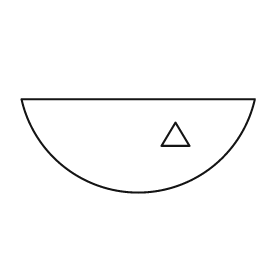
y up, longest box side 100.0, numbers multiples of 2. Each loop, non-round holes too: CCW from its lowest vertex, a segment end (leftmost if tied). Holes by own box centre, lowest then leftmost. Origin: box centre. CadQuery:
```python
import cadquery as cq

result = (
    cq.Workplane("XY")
    .moveTo(-50.0, 20.0)
    .threePointArc((0.0, -20.0), (50.0, 20.0))
    .close()
    .moveTo(10.0, 0.0)
    .lineTo(22.0, 0.0)
    .lineTo(16.0, 10.0)
    .close()
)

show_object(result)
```